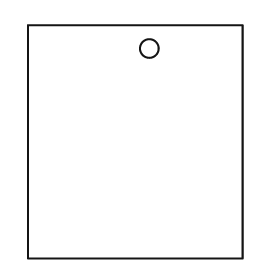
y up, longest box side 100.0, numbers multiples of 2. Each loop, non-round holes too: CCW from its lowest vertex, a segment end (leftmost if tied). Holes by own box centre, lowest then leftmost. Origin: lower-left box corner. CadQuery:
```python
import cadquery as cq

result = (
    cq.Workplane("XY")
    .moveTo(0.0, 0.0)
    .lineTo(92.0, 0.0)
    .lineTo(92.0, 100.0)
    .lineTo(0.0, 100.0)
    .close()
    .moveTo(52.0, 90.0)
    .circle(4.0)
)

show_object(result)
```